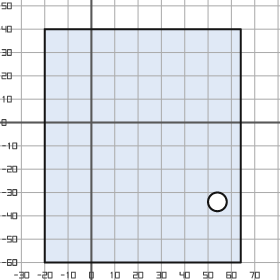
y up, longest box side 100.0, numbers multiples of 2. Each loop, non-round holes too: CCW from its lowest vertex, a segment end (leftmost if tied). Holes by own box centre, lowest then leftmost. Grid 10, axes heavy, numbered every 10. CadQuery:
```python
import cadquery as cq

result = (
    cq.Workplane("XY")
    .moveTo(-20.0, -60.0)
    .lineTo(64.0, -60.0)
    .lineTo(64.0, 40.0)
    .lineTo(-20.0, 40.0)
    .close()
    .moveTo(54.0, -34.0)
    .circle(4.0)
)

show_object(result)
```